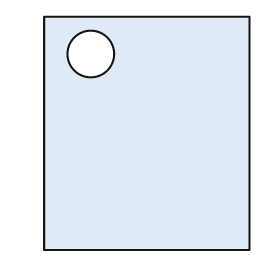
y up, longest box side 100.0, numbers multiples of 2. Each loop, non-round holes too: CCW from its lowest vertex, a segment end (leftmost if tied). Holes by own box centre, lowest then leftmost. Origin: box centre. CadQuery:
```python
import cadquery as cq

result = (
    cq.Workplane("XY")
    .moveTo(-44.0, -50.0)
    .lineTo(44.0, -50.0)
    .lineTo(44.0, 50.0)
    .lineTo(-44.0, 50.0)
    .close()
    .moveTo(-24.0, 34.0)
    .circle(10.0)
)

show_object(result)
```